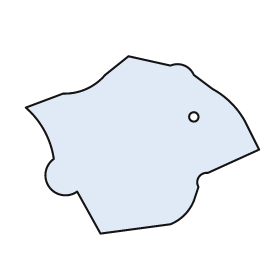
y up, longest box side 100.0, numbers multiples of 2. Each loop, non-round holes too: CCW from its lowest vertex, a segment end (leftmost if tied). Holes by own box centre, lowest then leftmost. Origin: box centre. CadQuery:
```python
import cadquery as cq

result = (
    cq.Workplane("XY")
    .moveTo(-18.0, -38.0)
    .lineTo(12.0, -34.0)
    .threePointArc((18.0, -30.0), (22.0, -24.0))
    .lineTo(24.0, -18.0)
    .threePointArc((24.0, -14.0), (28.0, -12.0))
    .lineTo(50.0, -2.0)
    .lineTo(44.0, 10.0)
    .threePointArc((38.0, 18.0), (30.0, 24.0))
    .lineTo(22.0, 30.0)
    .threePointArc((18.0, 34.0), (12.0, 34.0))
    .lineTo(-6.0, 38.0)
    .lineTo(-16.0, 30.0)
    .threePointArc((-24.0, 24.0), (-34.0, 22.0))
    .lineTo(-50.0, 16.0)
    .threePointArc((-42.0, 6.0), (-38.0, -6.0))
    .threePointArc((-40.0, -18.0), (-28.0, -20.0))
    .close()
    .moveTo(22.0, 12.0)
    .circle(2.0)
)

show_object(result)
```